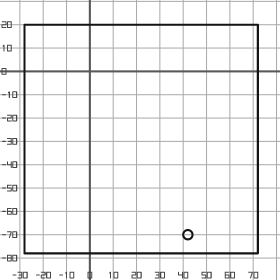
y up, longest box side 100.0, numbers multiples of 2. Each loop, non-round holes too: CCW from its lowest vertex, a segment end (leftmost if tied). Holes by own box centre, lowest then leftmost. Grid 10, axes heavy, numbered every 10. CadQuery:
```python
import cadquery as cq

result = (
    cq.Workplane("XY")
    .moveTo(-28.0, -78.0)
    .lineTo(72.0, -78.0)
    .lineTo(72.0, 20.0)
    .lineTo(-28.0, 20.0)
    .close()
    .moveTo(42.0, -70.0)
    .circle(2.0)
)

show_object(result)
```